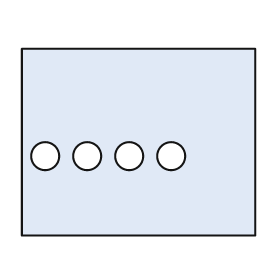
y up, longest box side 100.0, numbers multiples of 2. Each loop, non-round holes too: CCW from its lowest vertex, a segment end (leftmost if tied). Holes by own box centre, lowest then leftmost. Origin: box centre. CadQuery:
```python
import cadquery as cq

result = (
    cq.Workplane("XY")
    .moveTo(-50.0, -40.0)
    .lineTo(50.0, -40.0)
    .lineTo(50.0, 40.0)
    .lineTo(-50.0, 40.0)
    .close()
    .moveTo(-40.0, -6.0)
    .circle(6.0)
    .moveTo(-22.0, -6.0)
    .circle(6.0)
    .moveTo(-4.0, -6.0)
    .circle(6.0)
    .moveTo(14.0, -6.0)
    .circle(6.0)
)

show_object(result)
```